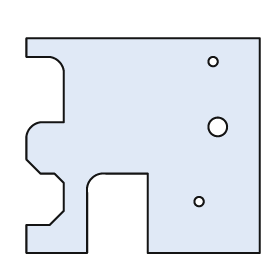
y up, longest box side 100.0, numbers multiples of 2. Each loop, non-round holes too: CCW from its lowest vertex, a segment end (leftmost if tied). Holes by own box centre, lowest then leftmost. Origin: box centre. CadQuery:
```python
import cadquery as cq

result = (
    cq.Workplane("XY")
    .moveTo(-50.0, -46.0)
    .lineTo(-24.0, -46.0)
    .lineTo(-24.0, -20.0)
    .threePointArc((-22.0, -14.0), (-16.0, -12.0))
    .lineTo(2.0, -12.0)
    .lineTo(2.0, -46.0)
    .lineTo(50.0, -46.0)
    .lineTo(50.0, 46.0)
    .lineTo(-50.0, 46.0)
    .lineTo(-50.0, 38.0)
    .lineTo(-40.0, 38.0)
    .threePointArc((-36.0, 36.0), (-34.0, 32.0))
    .lineTo(-34.0, 10.0)
    .lineTo(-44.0, 10.0)
    .threePointArc((-48.0, 8.0), (-50.0, 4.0))
    .lineTo(-50.0, -6.0)
    .lineTo(-44.0, -12.0)
    .lineTo(-38.0, -12.0)
    .lineTo(-34.0, -16.0)
    .lineTo(-34.0, -28.0)
    .lineTo(-40.0, -34.0)
    .lineTo(-50.0, -34.0)
    .close()
    .moveTo(24.0, -24.0)
    .circle(2.0)
    .moveTo(32.0, 8.0)
    .circle(4.0)
    .moveTo(30.0, 36.0)
    .circle(2.0)
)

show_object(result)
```